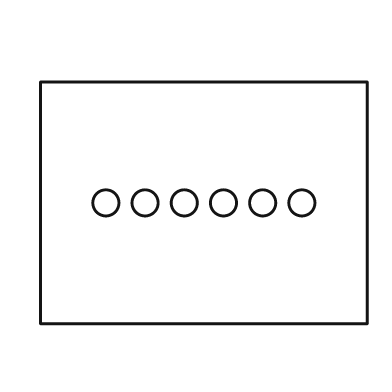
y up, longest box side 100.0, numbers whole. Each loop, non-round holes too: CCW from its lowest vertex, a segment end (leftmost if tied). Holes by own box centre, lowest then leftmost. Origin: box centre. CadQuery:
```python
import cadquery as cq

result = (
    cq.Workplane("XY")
    .moveTo(-50.0, -37.0)
    .lineTo(50.0, -37.0)
    .lineTo(50.0, 37.0)
    .lineTo(-50.0, 37.0)
    .close()
    .moveTo(-30.0, 0.0)
    .circle(4.0)
    .moveTo(-18.0, 0.0)
    .circle(4.0)
    .moveTo(-6.0, 0.0)
    .circle(4.0)
    .moveTo(6.0, 0.0)
    .circle(4.0)
    .moveTo(18.0, 0.0)
    .circle(4.0)
    .moveTo(30.0, 0.0)
    .circle(4.0)
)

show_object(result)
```